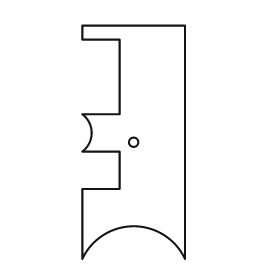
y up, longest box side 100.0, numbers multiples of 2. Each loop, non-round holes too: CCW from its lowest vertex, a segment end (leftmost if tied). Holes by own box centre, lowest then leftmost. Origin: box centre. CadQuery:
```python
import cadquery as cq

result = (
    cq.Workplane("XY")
    .moveTo(-22.0, -50.0)
    .threePointArc((0.0, -36.0), (22.0, -50.0))
    .lineTo(22.0, 50.0)
    .lineTo(-22.0, 50.0)
    .lineTo(-22.0, 44.0)
    .lineTo(-6.0, 44.0)
    .lineTo(-6.0, 12.0)
    .lineTo(-22.0, 12.0)
    .threePointArc((-18.0, 4.0), (-22.0, -4.0))
    .lineTo(-6.0, -4.0)
    .lineTo(-6.0, -20.0)
    .lineTo(-22.0, -20.0)
    .close()
    .moveTo(0.0, 0.0)
    .circle(2.0)
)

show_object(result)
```